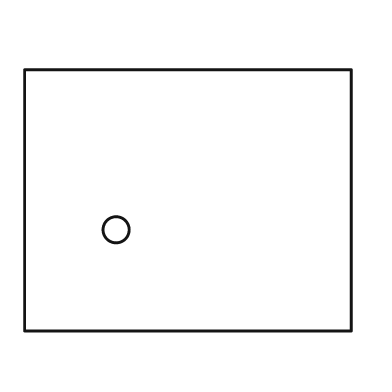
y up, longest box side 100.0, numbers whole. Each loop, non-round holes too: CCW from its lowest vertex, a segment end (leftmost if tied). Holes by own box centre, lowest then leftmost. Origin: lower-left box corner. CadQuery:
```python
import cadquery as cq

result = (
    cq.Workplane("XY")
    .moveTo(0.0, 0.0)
    .lineTo(100.0, 0.0)
    .lineTo(100.0, 80.0)
    .lineTo(0.0, 80.0)
    .close()
    .moveTo(28.0, 31.0)
    .circle(4.0)
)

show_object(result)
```